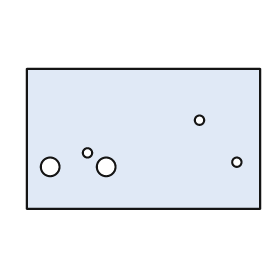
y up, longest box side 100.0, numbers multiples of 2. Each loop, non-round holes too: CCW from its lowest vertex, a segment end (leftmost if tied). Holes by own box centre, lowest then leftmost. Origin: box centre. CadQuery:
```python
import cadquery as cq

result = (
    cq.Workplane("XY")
    .moveTo(-50.0, -30.0)
    .lineTo(50.0, -30.0)
    .lineTo(50.0, 30.0)
    .lineTo(-50.0, 30.0)
    .close()
    .moveTo(-40.0, -12.0)
    .circle(4.0)
    .moveTo(-16.0, -12.0)
    .circle(4.0)
    .moveTo(40.0, -10.0)
    .circle(2.0)
    .moveTo(-24.0, -6.0)
    .circle(2.0)
    .moveTo(24.0, 8.0)
    .circle(2.0)
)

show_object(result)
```